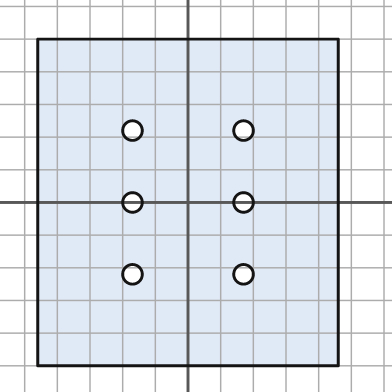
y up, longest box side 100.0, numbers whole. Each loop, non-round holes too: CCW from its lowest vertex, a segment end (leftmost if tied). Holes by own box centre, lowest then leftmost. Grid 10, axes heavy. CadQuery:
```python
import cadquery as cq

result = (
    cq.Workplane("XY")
    .moveTo(-46.0, -50.0)
    .lineTo(46.0, -50.0)
    .lineTo(46.0, 50.0)
    .lineTo(-46.0, 50.0)
    .close()
    .moveTo(-17.0, -22.0)
    .circle(3.0)
    .moveTo(17.0, -22.0)
    .circle(3.0)
    .moveTo(-17.0, 0.0)
    .circle(3.0)
    .moveTo(17.0, 0.0)
    .circle(3.0)
    .moveTo(-17.0, 22.0)
    .circle(3.0)
    .moveTo(17.0, 22.0)
    .circle(3.0)
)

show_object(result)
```